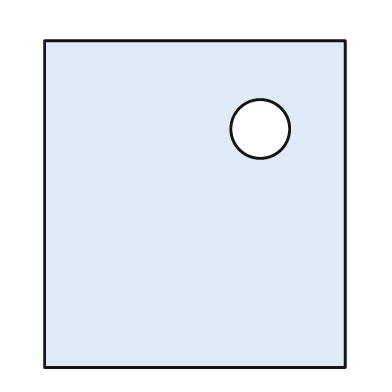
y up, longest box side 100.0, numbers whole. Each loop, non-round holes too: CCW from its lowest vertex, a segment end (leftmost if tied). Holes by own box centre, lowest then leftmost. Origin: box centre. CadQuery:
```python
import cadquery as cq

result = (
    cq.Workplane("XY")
    .moveTo(-46.0, -50.0)
    .lineTo(46.0, -50.0)
    .lineTo(46.0, 50.0)
    .lineTo(-46.0, 50.0)
    .close()
    .moveTo(20.0, 23.0)
    .circle(9.0)
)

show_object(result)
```